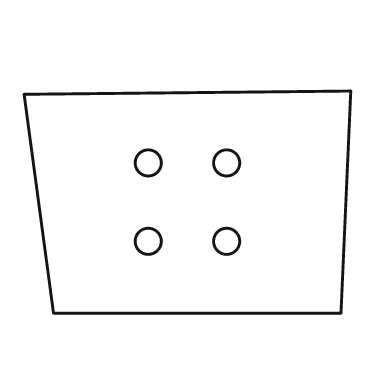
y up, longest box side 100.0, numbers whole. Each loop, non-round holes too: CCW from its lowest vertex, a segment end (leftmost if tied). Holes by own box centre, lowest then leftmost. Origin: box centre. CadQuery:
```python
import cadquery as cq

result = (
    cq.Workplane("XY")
    .moveTo(-41.0, -34.0)
    .lineTo(47.0, -34.0)
    .lineTo(50.0, 34.0)
    .lineTo(-50.0, 33.0)
    .close()
    .moveTo(-12.0, -12.0)
    .circle(4.0)
    .moveTo(12.0, -12.0)
    .circle(4.0)
    .moveTo(-12.0, 12.0)
    .circle(4.0)
    .moveTo(12.0, 12.0)
    .circle(4.0)
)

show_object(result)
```